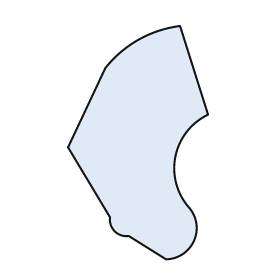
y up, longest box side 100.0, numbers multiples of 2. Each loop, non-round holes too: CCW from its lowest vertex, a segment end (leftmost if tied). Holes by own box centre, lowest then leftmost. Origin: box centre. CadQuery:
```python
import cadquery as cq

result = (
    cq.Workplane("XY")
    .moveTo(12.0, -50.0)
    .threePointArc((24.0, -42.0), (22.0, -28.0))
    .threePointArc((16.0, -6.0), (30.0, 12.0))
    .lineTo(18.0, 50.0)
    .threePointArc((0.0, 44.0), (-14.0, 32.0))
    .lineTo(-30.0, -2.0)
    .lineTo(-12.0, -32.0)
    .threePointArc((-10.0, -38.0), (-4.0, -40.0))
    .close()
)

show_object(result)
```